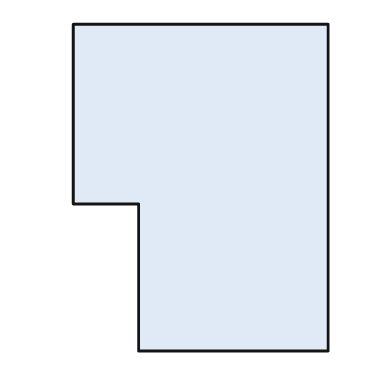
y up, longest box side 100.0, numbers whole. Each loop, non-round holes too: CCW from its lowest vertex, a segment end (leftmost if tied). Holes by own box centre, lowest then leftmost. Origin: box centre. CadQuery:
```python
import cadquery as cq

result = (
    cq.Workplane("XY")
    .moveTo(-19.0, -50.0)
    .lineTo(39.0, -50.0)
    .lineTo(39.0, 50.0)
    .lineTo(-39.0, 50.0)
    .lineTo(-39.0, -5.0)
    .lineTo(-19.0, -5.0)
    .close()
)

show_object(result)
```